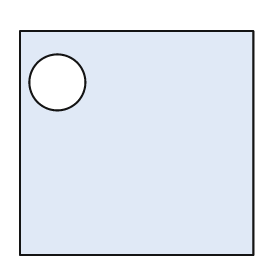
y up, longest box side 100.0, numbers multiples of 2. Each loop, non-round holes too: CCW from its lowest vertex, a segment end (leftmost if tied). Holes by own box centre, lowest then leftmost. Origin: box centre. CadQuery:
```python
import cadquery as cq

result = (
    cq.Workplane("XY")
    .moveTo(-50.0, -48.0)
    .lineTo(50.0, -48.0)
    .lineTo(50.0, 48.0)
    .lineTo(-50.0, 48.0)
    .close()
    .moveTo(-34.0, 26.0)
    .circle(12.0)
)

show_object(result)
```